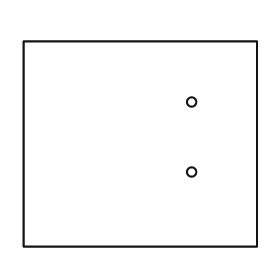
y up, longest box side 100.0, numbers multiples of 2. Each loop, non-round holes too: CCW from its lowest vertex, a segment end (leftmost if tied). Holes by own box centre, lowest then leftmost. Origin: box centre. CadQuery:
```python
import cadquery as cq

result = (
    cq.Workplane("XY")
    .moveTo(-50.0, -44.0)
    .lineTo(50.0, -44.0)
    .lineTo(50.0, 44.0)
    .lineTo(-50.0, 44.0)
    .close()
    .moveTo(22.0, -12.0)
    .circle(2.0)
    .moveTo(22.0, 18.0)
    .circle(2.0)
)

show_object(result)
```